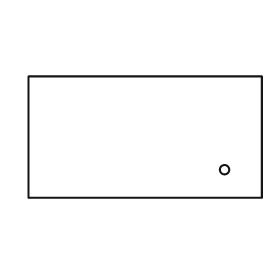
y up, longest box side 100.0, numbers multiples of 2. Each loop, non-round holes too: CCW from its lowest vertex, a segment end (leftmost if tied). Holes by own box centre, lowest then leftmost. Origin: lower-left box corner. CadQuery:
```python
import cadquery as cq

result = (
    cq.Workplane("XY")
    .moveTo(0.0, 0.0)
    .lineTo(100.0, 0.0)
    .lineTo(100.0, 52.0)
    .lineTo(0.0, 52.0)
    .close()
    .moveTo(84.0, 12.0)
    .circle(2.0)
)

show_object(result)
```